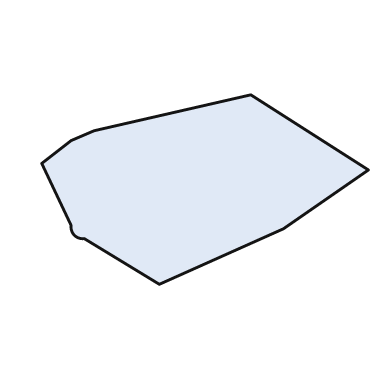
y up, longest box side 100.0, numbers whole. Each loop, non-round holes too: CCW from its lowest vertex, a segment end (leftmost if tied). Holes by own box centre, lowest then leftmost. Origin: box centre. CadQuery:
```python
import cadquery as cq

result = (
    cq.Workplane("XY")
    .moveTo(-14.0, -29.0)
    .lineTo(24.0, -12.0)
    .lineTo(50.0, 6.0)
    .lineTo(14.0, 29.0)
    .lineTo(-34.0, 18.0)
    .lineTo(-41.0, 15.0)
    .lineTo(-50.0, 8.0)
    .lineTo(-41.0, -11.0)
    .threePointArc((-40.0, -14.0), (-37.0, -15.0))
    .close()
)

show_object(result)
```